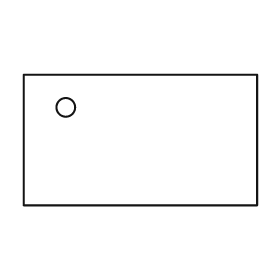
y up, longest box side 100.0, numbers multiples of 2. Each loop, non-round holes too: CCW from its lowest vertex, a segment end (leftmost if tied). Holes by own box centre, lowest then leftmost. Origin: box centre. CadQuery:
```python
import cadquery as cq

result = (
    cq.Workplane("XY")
    .moveTo(-50.0, -28.0)
    .lineTo(50.0, -28.0)
    .lineTo(50.0, 28.0)
    .lineTo(-50.0, 28.0)
    .close()
    .moveTo(-32.0, 14.0)
    .circle(4.0)
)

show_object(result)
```